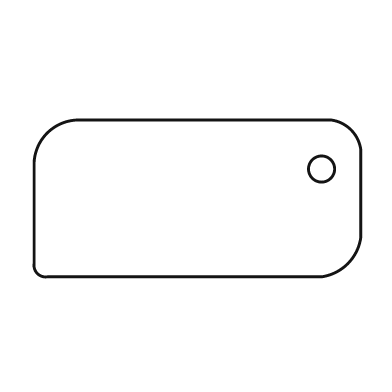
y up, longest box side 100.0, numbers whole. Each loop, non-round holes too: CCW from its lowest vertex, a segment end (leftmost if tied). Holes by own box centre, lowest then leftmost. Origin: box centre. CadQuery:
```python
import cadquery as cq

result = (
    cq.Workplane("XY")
    .moveTo(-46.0, -24.0)
    .lineTo(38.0, -24.0)
    .threePointArc((46.0, -20.0), (50.0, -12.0))
    .lineTo(50.0, 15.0)
    .threePointArc((47.0, 21.0), (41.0, 24.0))
    .lineTo(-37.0, 24.0)
    .threePointArc((-46.0, 20.0), (-50.0, 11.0))
    .lineTo(-50.0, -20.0)
    .threePointArc((-49.0, -23.0), (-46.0, -24.0))
    .close()
    .moveTo(38.0, 9.0)
    .circle(4.0)
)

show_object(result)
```